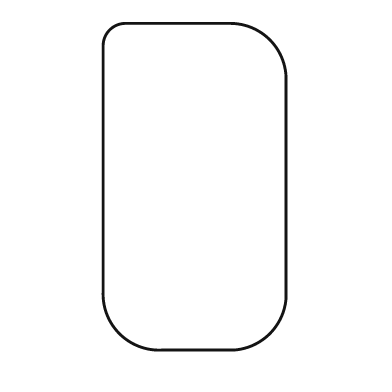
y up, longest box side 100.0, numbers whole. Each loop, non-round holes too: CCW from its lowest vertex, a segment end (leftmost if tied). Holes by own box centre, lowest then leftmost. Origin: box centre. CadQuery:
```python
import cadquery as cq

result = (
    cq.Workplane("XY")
    .moveTo(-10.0, -50.0)
    .lineTo(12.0, -50.0)
    .threePointArc((23.0, -45.0), (28.0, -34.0))
    .lineTo(28.0, 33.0)
    .threePointArc((23.0, 45.0), (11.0, 50.0))
    .lineTo(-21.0, 50.0)
    .threePointArc((-26.0, 48.0), (-28.0, 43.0))
    .lineTo(-28.0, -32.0)
    .threePointArc((-23.0, -45.0), (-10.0, -50.0))
    .close()
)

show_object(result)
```